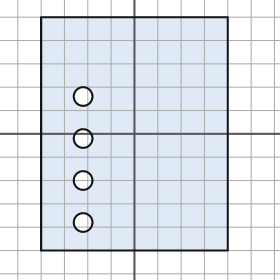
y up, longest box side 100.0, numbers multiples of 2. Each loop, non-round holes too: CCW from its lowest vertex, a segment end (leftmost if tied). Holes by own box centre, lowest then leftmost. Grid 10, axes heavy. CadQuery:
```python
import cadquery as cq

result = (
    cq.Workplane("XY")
    .moveTo(-40.0, -50.0)
    .lineTo(40.0, -50.0)
    .lineTo(40.0, 50.0)
    .lineTo(-40.0, 50.0)
    .close()
    .moveTo(-22.0, -38.0)
    .circle(4.0)
    .moveTo(-22.0, -20.0)
    .circle(4.0)
    .moveTo(-22.0, -2.0)
    .circle(4.0)
    .moveTo(-22.0, 16.0)
    .circle(4.0)
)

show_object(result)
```